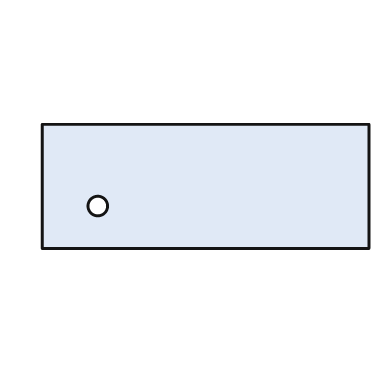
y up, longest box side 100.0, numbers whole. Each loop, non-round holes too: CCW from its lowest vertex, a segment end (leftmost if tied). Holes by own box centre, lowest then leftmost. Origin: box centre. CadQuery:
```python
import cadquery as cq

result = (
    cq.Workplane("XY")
    .moveTo(-50.0, -19.0)
    .lineTo(50.0, -19.0)
    .lineTo(50.0, 19.0)
    .lineTo(-50.0, 19.0)
    .close()
    .moveTo(-33.0, -6.0)
    .circle(3.0)
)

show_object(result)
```